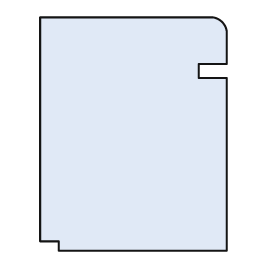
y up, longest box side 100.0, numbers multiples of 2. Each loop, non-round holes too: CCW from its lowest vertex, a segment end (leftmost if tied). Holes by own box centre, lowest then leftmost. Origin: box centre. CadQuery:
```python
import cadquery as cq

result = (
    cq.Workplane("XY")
    .moveTo(-32.0, -50.0)
    .lineTo(40.0, -50.0)
    .lineTo(40.0, 24.0)
    .lineTo(28.0, 24.0)
    .lineTo(28.0, 30.0)
    .lineTo(40.0, 30.0)
    .lineTo(40.0, 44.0)
    .threePointArc((38.0, 48.0), (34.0, 50.0))
    .lineTo(-40.0, 50.0)
    .lineTo(-40.0, -46.0)
    .lineTo(-32.0, -46.0)
    .close()
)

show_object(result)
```